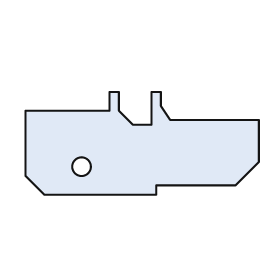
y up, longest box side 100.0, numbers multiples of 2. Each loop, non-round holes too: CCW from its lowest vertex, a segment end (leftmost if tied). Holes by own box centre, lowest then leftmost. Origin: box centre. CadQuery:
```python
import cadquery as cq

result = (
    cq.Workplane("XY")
    .moveTo(-42.0, -22.0)
    .lineTo(6.0, -22.0)
    .lineTo(6.0, -18.0)
    .lineTo(40.0, -18.0)
    .lineTo(50.0, -8.0)
    .lineTo(50.0, 10.0)
    .lineTo(12.0, 10.0)
    .lineTo(8.0, 16.0)
    .lineTo(8.0, 22.0)
    .lineTo(4.0, 22.0)
    .lineTo(4.0, 8.0)
    .lineTo(-4.0, 8.0)
    .lineTo(-10.0, 14.0)
    .lineTo(-10.0, 22.0)
    .lineTo(-14.0, 22.0)
    .lineTo(-14.0, 14.0)
    .lineTo(-50.0, 14.0)
    .lineTo(-50.0, -14.0)
    .close()
    .moveTo(-26.0, -10.0)
    .circle(4.0)
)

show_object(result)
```